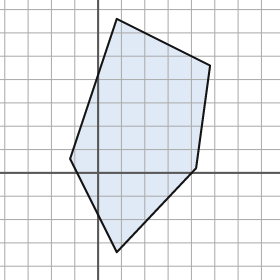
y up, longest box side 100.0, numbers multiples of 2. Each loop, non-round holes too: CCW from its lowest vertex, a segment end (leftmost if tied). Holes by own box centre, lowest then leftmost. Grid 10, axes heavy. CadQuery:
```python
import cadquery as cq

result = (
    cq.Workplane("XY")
    .moveTo(8.0, -34.0)
    .lineTo(42.0, 2.0)
    .lineTo(48.0, 46.0)
    .lineTo(8.0, 66.0)
    .lineTo(-12.0, 6.0)
    .close()
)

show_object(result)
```